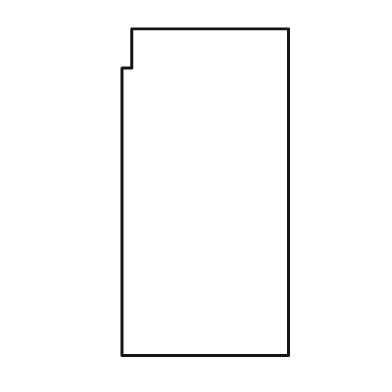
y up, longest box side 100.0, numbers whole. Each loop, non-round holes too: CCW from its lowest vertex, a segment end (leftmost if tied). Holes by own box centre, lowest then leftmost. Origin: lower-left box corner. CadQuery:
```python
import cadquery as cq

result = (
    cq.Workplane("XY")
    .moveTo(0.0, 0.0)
    .lineTo(51.0, 0.0)
    .lineTo(51.0, 100.0)
    .lineTo(3.0, 100.0)
    .lineTo(3.0, 88.0)
    .lineTo(0.0, 88.0)
    .close()
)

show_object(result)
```